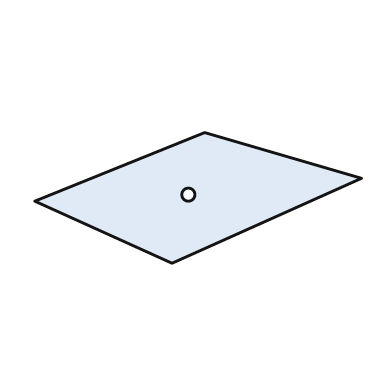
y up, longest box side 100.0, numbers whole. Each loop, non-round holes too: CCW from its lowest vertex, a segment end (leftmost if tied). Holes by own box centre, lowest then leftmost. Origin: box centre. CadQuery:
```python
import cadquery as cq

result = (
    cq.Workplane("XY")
    .moveTo(-8.0, -20.0)
    .lineTo(50.0, 6.0)
    .lineTo(2.0, 20.0)
    .lineTo(-50.0, -1.0)
    .close()
    .moveTo(-3.0, 1.0)
    .circle(2.0)
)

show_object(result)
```